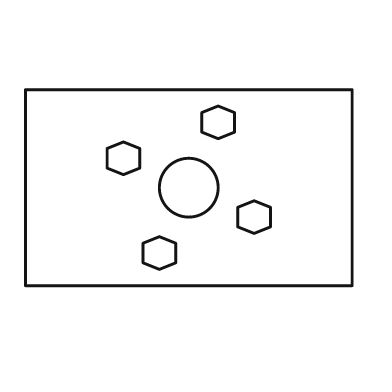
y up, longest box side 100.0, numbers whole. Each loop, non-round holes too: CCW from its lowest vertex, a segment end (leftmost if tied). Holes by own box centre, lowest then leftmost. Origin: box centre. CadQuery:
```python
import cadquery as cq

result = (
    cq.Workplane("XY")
    .moveTo(-50.0, -30.0)
    .lineTo(50.0, -30.0)
    .lineTo(50.0, 30.0)
    .lineTo(-50.0, 30.0)
    .close()
    .moveTo(-9.0, -25.0)
    .lineTo(-4.0, -23.0)
    .lineTo(-4.0, -17.0)
    .lineTo(-9.0, -15.0)
    .lineTo(-14.0, -17.0)
    .lineTo(-14.0, -23.0)
    .close()
    .moveTo(20.0, -14.0)
    .lineTo(25.0, -12.0)
    .lineTo(25.0, -6.0)
    .lineTo(20.0, -4.0)
    .lineTo(15.0, -6.0)
    .lineTo(15.0, -12.0)
    .close()
    .moveTo(0.0, 0.0)
    .circle(9.0)
    .moveTo(-20.0, 4.0)
    .lineTo(-15.0, 6.0)
    .lineTo(-15.0, 12.0)
    .lineTo(-20.0, 14.0)
    .lineTo(-25.0, 12.0)
    .lineTo(-25.0, 6.0)
    .close()
    .moveTo(9.0, 15.0)
    .lineTo(14.0, 17.0)
    .lineTo(14.0, 23.0)
    .lineTo(9.0, 25.0)
    .lineTo(4.0, 23.0)
    .lineTo(4.0, 17.0)
    .close()
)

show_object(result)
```